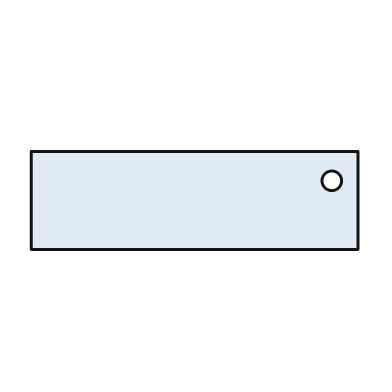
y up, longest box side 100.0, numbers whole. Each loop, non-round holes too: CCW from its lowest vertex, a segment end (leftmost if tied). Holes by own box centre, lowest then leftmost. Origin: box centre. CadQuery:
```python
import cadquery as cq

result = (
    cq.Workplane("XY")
    .moveTo(-50.0, -15.0)
    .lineTo(50.0, -15.0)
    .lineTo(50.0, 15.0)
    .lineTo(-50.0, 15.0)
    .close()
    .moveTo(42.0, 6.0)
    .circle(3.0)
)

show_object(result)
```